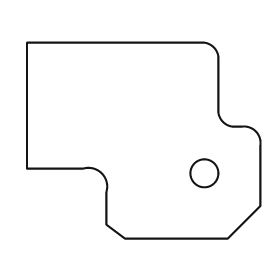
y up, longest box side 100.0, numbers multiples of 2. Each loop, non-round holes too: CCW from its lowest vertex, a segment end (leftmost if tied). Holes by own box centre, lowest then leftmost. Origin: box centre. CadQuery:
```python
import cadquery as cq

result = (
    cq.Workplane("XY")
    .moveTo(-8.0, -42.0)
    .lineTo(36.0, -42.0)
    .lineTo(50.0, -28.0)
    .lineTo(50.0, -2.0)
    .threePointArc((48.0, 4.0), (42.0, 6.0))
    .lineTo(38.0, 6.0)
    .threePointArc((34.0, 8.0), (32.0, 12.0))
    .lineTo(32.0, 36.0)
    .threePointArc((30.0, 40.0), (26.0, 42.0))
    .lineTo(-50.0, 42.0)
    .lineTo(-50.0, -12.0)
    .lineTo(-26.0, -12.0)
    .threePointArc((-18.0, -14.0), (-16.0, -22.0))
    .lineTo(-16.0, -36.0)
    .close()
    .moveTo(26.0, -14.0)
    .circle(6.0)
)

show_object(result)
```